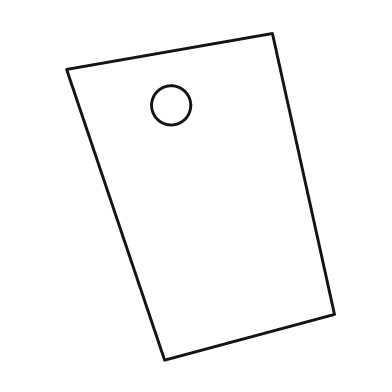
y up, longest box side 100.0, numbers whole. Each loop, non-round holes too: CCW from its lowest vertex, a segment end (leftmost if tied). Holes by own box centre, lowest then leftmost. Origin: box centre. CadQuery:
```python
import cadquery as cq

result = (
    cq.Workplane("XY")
    .moveTo(-11.0, -50.0)
    .lineTo(41.0, -36.0)
    .lineTo(22.0, 50.0)
    .lineTo(-41.0, 39.0)
    .close()
    .moveTo(-9.0, 28.0)
    .circle(6.0)
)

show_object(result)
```